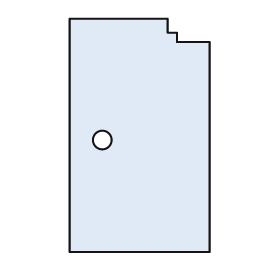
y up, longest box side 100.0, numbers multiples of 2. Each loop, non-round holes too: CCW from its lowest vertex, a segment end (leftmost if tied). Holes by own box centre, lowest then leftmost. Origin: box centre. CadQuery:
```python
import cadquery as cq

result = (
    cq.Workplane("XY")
    .moveTo(-30.0, -50.0)
    .lineTo(30.0, -50.0)
    .lineTo(30.0, 40.0)
    .lineTo(16.0, 40.0)
    .lineTo(16.0, 44.0)
    .lineTo(12.0, 44.0)
    .lineTo(12.0, 50.0)
    .lineTo(-30.0, 50.0)
    .close()
    .moveTo(-16.0, -2.0)
    .circle(4.0)
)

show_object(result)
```